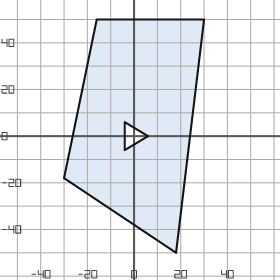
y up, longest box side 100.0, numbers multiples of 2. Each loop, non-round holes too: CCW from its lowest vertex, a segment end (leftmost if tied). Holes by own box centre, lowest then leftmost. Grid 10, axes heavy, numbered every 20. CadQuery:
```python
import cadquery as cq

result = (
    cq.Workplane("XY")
    .moveTo(18.0, -50.0)
    .lineTo(30.0, 50.0)
    .lineTo(-16.0, 50.0)
    .lineTo(-30.0, -18.0)
    .close()
    .moveTo(-4.0, -6.0)
    .lineTo(6.0, 0.0)
    .lineTo(-4.0, 6.0)
    .close()
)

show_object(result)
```